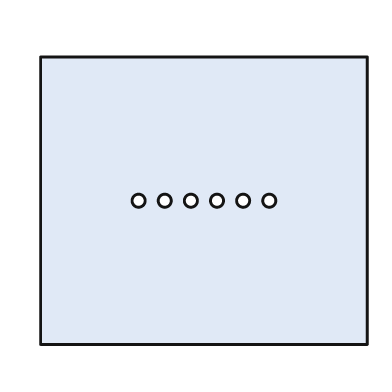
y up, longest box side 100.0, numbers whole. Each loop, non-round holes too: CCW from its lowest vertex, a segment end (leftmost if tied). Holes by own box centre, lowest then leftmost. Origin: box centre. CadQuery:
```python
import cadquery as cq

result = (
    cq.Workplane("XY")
    .moveTo(-50.0, -44.0)
    .lineTo(50.0, -44.0)
    .lineTo(50.0, 44.0)
    .lineTo(-50.0, 44.0)
    .close()
    .moveTo(-20.0, 0.0)
    .circle(2.0)
    .moveTo(-12.0, 0.0)
    .circle(2.0)
    .moveTo(-4.0, 0.0)
    .circle(2.0)
    .moveTo(4.0, 0.0)
    .circle(2.0)
    .moveTo(12.0, 0.0)
    .circle(2.0)
    .moveTo(20.0, 0.0)
    .circle(2.0)
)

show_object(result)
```